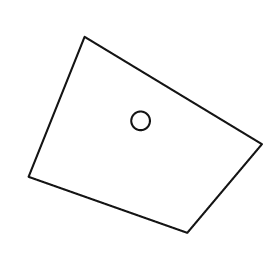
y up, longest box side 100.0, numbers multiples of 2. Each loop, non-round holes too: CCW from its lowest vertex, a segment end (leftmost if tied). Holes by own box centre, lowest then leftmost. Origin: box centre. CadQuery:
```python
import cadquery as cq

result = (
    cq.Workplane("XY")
    .moveTo(18.0, -42.0)
    .lineTo(50.0, -4.0)
    .lineTo(-26.0, 42.0)
    .lineTo(-50.0, -18.0)
    .close()
    .moveTo(-2.0, 6.0)
    .circle(4.0)
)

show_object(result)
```